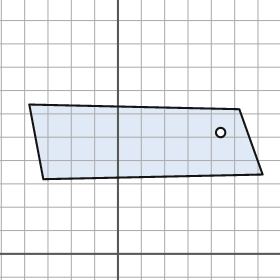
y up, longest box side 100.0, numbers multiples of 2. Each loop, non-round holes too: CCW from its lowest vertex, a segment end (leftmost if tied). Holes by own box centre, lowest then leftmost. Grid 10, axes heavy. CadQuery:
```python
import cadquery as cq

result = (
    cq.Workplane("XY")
    .moveTo(-32.0, 32.0)
    .lineTo(62.0, 34.0)
    .lineTo(52.0, 62.0)
    .lineTo(-38.0, 64.0)
    .close()
    .moveTo(44.0, 52.0)
    .circle(2.0)
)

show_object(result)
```